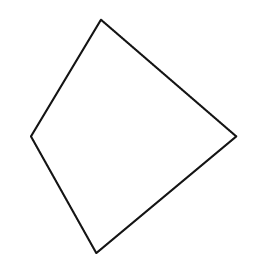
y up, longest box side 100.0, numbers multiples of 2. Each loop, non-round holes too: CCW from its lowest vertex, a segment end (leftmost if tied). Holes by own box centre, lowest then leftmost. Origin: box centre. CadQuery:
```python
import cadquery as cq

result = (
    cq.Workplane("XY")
    .moveTo(-16.0, -50.0)
    .lineTo(44.0, 0.0)
    .lineTo(-14.0, 50.0)
    .lineTo(-44.0, 0.0)
    .close()
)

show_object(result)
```